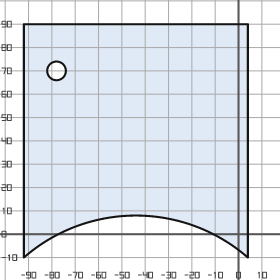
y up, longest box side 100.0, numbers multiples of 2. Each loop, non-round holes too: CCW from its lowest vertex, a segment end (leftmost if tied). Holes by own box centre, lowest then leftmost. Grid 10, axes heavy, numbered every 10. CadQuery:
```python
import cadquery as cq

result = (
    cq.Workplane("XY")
    .moveTo(-92.0, -10.0)
    .threePointArc((-44.0, 8.0), (4.0, -10.0))
    .lineTo(4.0, 90.0)
    .lineTo(-92.0, 90.0)
    .close()
    .moveTo(-78.0, 70.0)
    .circle(4.0)
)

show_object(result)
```